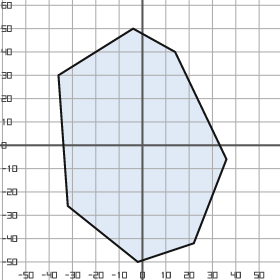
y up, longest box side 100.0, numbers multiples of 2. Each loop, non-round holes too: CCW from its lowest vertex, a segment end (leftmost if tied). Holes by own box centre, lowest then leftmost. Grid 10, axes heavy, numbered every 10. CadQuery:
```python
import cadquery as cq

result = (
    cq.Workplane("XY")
    .moveTo(-2.0, -50.0)
    .lineTo(22.0, -42.0)
    .lineTo(36.0, -6.0)
    .lineTo(14.0, 40.0)
    .lineTo(-4.0, 50.0)
    .lineTo(-36.0, 30.0)
    .lineTo(-32.0, -26.0)
    .close()
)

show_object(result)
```